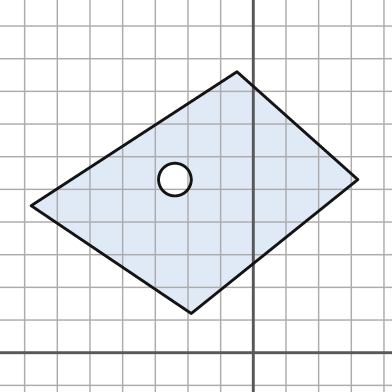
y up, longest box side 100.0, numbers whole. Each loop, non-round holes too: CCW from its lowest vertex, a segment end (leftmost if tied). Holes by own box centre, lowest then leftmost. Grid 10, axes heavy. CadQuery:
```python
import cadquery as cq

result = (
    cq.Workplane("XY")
    .moveTo(-19.0, 12.0)
    .lineTo(32.0, 53.0)
    .lineTo(-5.0, 86.0)
    .lineTo(-68.0, 45.0)
    .close()
    .moveTo(-24.0, 53.0)
    .circle(5.0)
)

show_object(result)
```